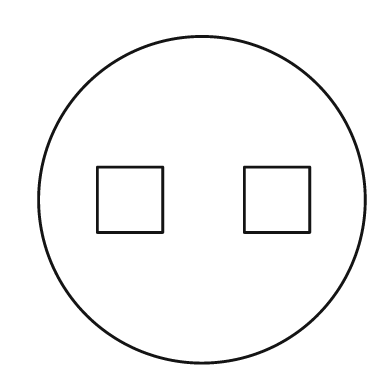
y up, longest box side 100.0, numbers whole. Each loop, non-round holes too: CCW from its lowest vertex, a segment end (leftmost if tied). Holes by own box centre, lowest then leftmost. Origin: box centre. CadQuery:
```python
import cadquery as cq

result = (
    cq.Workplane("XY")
    .moveTo(0.0, 0.0)
    .circle(50.0)
    .moveTo(-32.0, -10.0)
    .lineTo(-12.0, -10.0)
    .lineTo(-12.0, 10.0)
    .lineTo(-32.0, 10.0)
    .close()
    .moveTo(13.0, -10.0)
    .lineTo(33.0, -10.0)
    .lineTo(33.0, 10.0)
    .lineTo(13.0, 10.0)
    .close()
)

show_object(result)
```